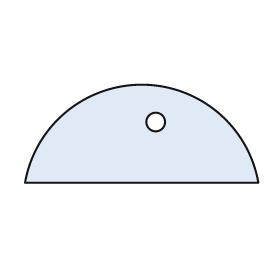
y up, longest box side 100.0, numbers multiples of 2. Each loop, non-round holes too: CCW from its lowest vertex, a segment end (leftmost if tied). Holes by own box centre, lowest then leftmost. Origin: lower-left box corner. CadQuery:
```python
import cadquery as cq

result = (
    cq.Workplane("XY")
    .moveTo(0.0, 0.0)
    .lineTo(100.0, 0.0)
    .threePointArc((50.0, 42.0), (0.0, 0.0))
    .close()
    .moveTo(56.0, 26.0)
    .circle(4.0)
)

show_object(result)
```